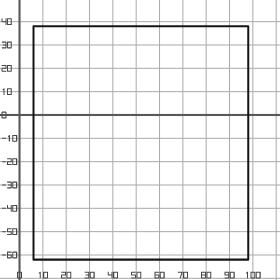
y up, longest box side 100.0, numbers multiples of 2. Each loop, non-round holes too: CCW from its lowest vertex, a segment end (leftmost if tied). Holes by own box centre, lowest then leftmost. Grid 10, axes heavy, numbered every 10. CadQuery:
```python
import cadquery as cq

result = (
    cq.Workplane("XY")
    .moveTo(6.0, -62.0)
    .lineTo(98.0, -62.0)
    .lineTo(98.0, 38.0)
    .lineTo(6.0, 38.0)
    .close()
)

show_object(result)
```